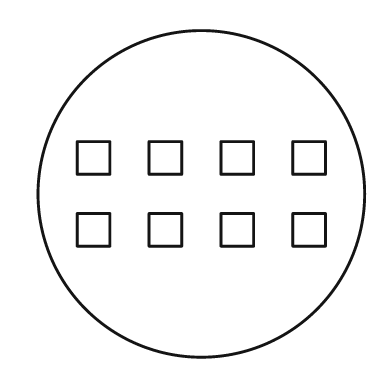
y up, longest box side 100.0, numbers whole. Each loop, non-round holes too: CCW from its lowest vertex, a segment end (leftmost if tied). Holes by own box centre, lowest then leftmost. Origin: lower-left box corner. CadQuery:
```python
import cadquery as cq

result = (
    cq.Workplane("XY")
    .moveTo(50.0, 50.0)
    .circle(50.0)
    .moveTo(12.0, 34.0)
    .lineTo(22.0, 34.0)
    .lineTo(22.0, 44.0)
    .lineTo(12.0, 44.0)
    .close()
    .moveTo(34.0, 34.0)
    .lineTo(44.0, 34.0)
    .lineTo(44.0, 44.0)
    .lineTo(34.0, 44.0)
    .close()
    .moveTo(56.0, 34.0)
    .lineTo(66.0, 34.0)
    .lineTo(66.0, 44.0)
    .lineTo(56.0, 44.0)
    .close()
    .moveTo(78.0, 34.0)
    .lineTo(88.0, 34.0)
    .lineTo(88.0, 44.0)
    .lineTo(78.0, 44.0)
    .close()
    .moveTo(12.0, 56.0)
    .lineTo(22.0, 56.0)
    .lineTo(22.0, 66.0)
    .lineTo(12.0, 66.0)
    .close()
    .moveTo(34.0, 56.0)
    .lineTo(44.0, 56.0)
    .lineTo(44.0, 66.0)
    .lineTo(34.0, 66.0)
    .close()
    .moveTo(56.0, 56.0)
    .lineTo(66.0, 56.0)
    .lineTo(66.0, 66.0)
    .lineTo(56.0, 66.0)
    .close()
    .moveTo(78.0, 56.0)
    .lineTo(88.0, 56.0)
    .lineTo(88.0, 66.0)
    .lineTo(78.0, 66.0)
    .close()
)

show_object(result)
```